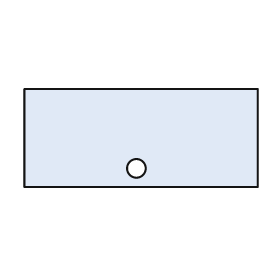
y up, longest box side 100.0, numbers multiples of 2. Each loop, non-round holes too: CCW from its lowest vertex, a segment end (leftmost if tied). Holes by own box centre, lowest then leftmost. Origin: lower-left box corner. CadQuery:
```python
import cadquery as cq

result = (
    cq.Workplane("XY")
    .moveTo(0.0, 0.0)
    .lineTo(100.0, 0.0)
    .lineTo(100.0, 42.0)
    .lineTo(0.0, 42.0)
    .close()
    .moveTo(48.0, 8.0)
    .circle(4.0)
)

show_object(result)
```